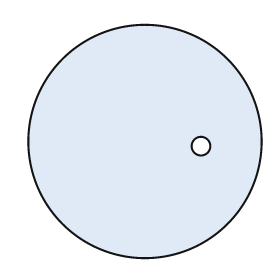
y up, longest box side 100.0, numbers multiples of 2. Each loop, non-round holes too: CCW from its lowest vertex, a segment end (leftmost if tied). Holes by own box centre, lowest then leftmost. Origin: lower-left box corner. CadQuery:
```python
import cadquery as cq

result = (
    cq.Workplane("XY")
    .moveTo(50.0, 50.0)
    .circle(50.0)
    .moveTo(74.0, 48.0)
    .circle(4.0)
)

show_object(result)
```